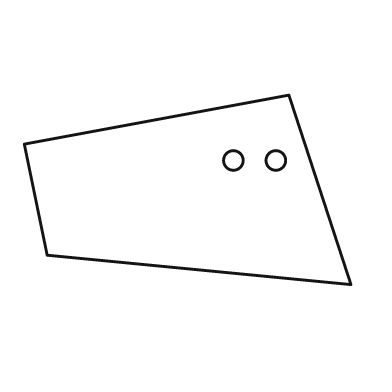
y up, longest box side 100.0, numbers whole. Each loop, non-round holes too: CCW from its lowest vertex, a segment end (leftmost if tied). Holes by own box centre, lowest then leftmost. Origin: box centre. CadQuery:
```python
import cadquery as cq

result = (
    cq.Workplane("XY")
    .moveTo(50.0, -29.0)
    .lineTo(31.0, 29.0)
    .lineTo(-50.0, 14.0)
    .lineTo(-43.0, -20.0)
    .close()
    .moveTo(14.0, 9.0)
    .circle(3.0)
    .moveTo(27.0, 9.0)
    .circle(3.0)
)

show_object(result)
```